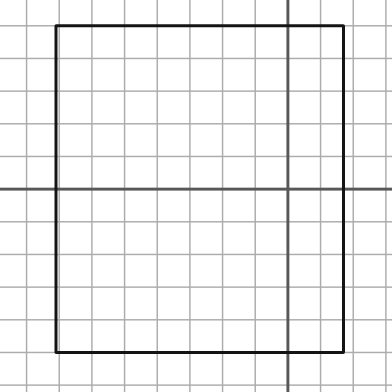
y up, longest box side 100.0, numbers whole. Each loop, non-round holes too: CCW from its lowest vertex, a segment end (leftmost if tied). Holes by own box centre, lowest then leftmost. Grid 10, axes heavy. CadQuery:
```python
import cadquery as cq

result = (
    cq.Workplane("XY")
    .moveTo(-71.0, -50.0)
    .lineTo(17.0, -50.0)
    .lineTo(17.0, 50.0)
    .lineTo(-71.0, 50.0)
    .close()
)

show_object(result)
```